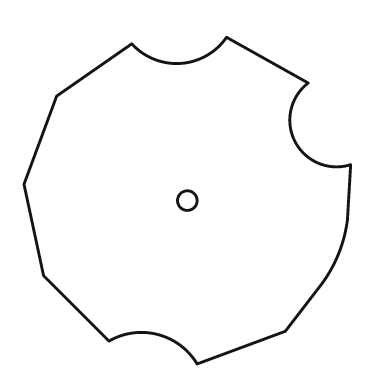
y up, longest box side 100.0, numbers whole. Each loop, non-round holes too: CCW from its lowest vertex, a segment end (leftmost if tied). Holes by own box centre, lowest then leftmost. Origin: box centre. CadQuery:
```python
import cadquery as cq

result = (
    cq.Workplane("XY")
    .moveTo(3.0, -50.0)
    .lineTo(30.0, -40.0)
    .lineTo(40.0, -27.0)
    .threePointArc((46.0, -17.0), (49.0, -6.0))
    .lineTo(50.0, 11.0)
    .threePointArc((33.0, 18.0), (37.0, 36.0))
    .lineTo(12.0, 50.0)
    .threePointArc((-2.0, 42.0), (-17.0, 48.0))
    .lineTo(-40.0, 32.0)
    .lineTo(-50.0, 5.0)
    .lineTo(-44.0, -23.0)
    .lineTo(-24.0, -43.0)
    .threePointArc((-9.0, -41.0), (3.0, -50.0))
    .close()
    .moveTo(0.0, 0.0)
    .circle(3.0)
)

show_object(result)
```